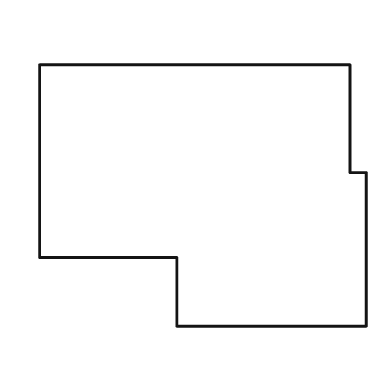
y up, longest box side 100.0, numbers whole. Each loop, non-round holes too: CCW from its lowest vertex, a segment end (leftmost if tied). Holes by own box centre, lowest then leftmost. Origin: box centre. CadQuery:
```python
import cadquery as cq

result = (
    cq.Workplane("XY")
    .moveTo(-8.0, -40.0)
    .lineTo(50.0, -40.0)
    .lineTo(50.0, 7.0)
    .lineTo(45.0, 7.0)
    .lineTo(45.0, 40.0)
    .lineTo(-50.0, 40.0)
    .lineTo(-50.0, -19.0)
    .lineTo(-8.0, -19.0)
    .close()
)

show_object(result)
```